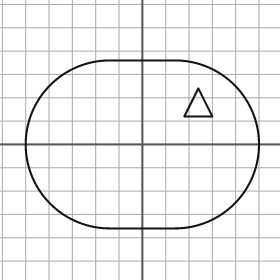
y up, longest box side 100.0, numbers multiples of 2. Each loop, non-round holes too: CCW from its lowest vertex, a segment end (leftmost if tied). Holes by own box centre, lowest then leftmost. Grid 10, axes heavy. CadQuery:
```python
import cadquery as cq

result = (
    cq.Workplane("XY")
    .moveTo(-14.0, -36.0)
    .lineTo(14.0, -36.0)
    .threePointArc((50.0, 0.0), (14.0, 36.0))
    .lineTo(-14.0, 36.0)
    .threePointArc((-50.0, 0.0), (-14.0, -36.0))
    .close()
    .moveTo(18.0, 12.0)
    .lineTo(30.0, 12.0)
    .lineTo(24.0, 24.0)
    .close()
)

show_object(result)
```